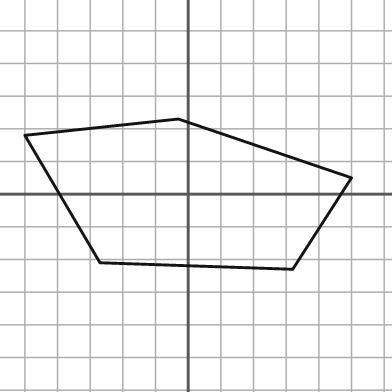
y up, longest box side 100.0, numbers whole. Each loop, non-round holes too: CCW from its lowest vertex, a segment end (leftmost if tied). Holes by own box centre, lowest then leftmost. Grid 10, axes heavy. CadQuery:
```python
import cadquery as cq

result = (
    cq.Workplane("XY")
    .moveTo(32.0, -23.0)
    .lineTo(50.0, 5.0)
    .lineTo(-3.0, 23.0)
    .lineTo(-50.0, 18.0)
    .lineTo(-27.0, -21.0)
    .close()
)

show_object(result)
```